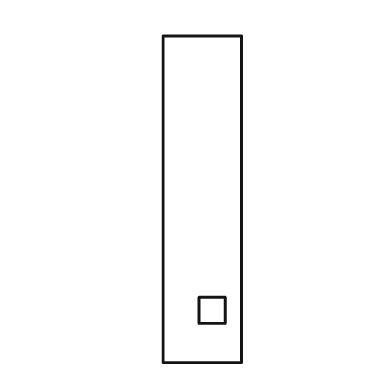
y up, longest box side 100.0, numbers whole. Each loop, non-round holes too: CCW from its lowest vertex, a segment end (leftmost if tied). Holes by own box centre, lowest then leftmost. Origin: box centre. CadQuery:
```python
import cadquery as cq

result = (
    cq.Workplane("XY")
    .moveTo(-12.0, -50.0)
    .lineTo(12.0, -50.0)
    .lineTo(12.0, 50.0)
    .lineTo(-12.0, 50.0)
    .close()
    .moveTo(-1.0, -38.0)
    .lineTo(7.0, -38.0)
    .lineTo(7.0, -30.0)
    .lineTo(-1.0, -30.0)
    .close()
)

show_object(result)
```